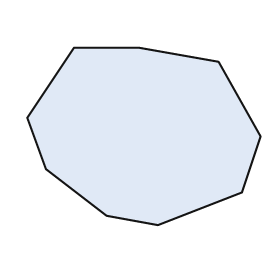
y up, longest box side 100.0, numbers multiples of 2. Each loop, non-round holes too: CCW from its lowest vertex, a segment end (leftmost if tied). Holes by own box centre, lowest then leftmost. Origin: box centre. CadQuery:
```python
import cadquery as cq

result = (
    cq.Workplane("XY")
    .moveTo(6.0, -38.0)
    .lineTo(42.0, -24.0)
    .lineTo(50.0, 0.0)
    .lineTo(32.0, 32.0)
    .lineTo(-2.0, 38.0)
    .lineTo(-30.0, 38.0)
    .lineTo(-50.0, 8.0)
    .lineTo(-42.0, -14.0)
    .lineTo(-16.0, -34.0)
    .close()
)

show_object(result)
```